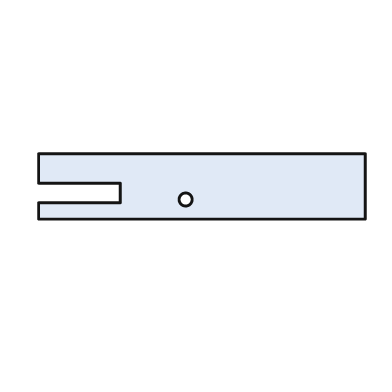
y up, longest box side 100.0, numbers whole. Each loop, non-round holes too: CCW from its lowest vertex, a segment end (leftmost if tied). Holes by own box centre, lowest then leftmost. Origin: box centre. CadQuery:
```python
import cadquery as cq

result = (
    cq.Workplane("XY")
    .moveTo(-50.0, -10.0)
    .lineTo(50.0, -10.0)
    .lineTo(50.0, 10.0)
    .lineTo(-50.0, 10.0)
    .lineTo(-50.0, 1.0)
    .lineTo(-25.0, 1.0)
    .lineTo(-25.0, -5.0)
    .lineTo(-50.0, -5.0)
    .close()
    .moveTo(-5.0, -4.0)
    .circle(2.0)
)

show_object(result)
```